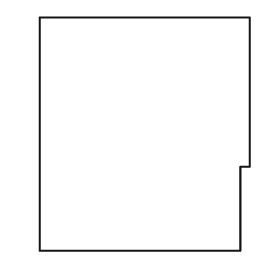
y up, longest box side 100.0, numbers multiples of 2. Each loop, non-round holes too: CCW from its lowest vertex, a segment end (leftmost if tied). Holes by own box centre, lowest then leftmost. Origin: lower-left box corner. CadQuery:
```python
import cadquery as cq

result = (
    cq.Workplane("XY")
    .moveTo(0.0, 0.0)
    .lineTo(86.0, 0.0)
    .lineTo(86.0, 36.0)
    .lineTo(90.0, 36.0)
    .lineTo(90.0, 100.0)
    .lineTo(0.0, 100.0)
    .close()
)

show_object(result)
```